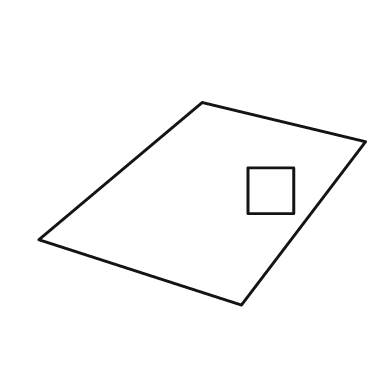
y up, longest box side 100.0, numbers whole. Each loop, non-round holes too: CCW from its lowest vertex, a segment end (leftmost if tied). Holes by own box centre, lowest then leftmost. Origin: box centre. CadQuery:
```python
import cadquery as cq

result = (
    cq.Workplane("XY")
    .moveTo(12.0, -31.0)
    .lineTo(50.0, 19.0)
    .lineTo(0.0, 31.0)
    .lineTo(-50.0, -11.0)
    .close()
    .moveTo(14.0, -3.0)
    .lineTo(28.0, -3.0)
    .lineTo(28.0, 11.0)
    .lineTo(14.0, 11.0)
    .close()
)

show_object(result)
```